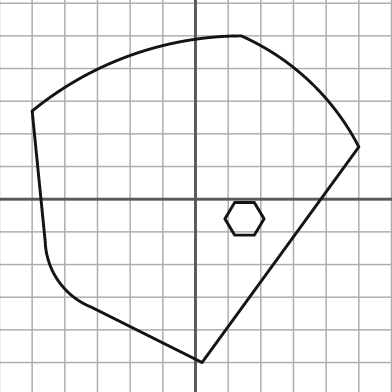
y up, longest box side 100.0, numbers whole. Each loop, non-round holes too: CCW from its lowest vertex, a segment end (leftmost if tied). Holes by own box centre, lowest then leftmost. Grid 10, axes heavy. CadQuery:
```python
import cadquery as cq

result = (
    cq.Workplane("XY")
    .moveTo(2.0, -50.0)
    .lineTo(50.0, 16.0)
    .threePointArc((35.0, 36.0), (14.0, 50.0))
    .threePointArc((-20.0, 44.0), (-50.0, 27.0))
    .lineTo(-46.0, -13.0)
    .threePointArc((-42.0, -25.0), (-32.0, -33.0))
    .close()
    .moveTo(12.0, -11.0)
    .lineTo(18.0, -11.0)
    .lineTo(21.0, -6.0)
    .lineTo(18.0, -1.0)
    .lineTo(12.0, -1.0)
    .lineTo(9.0, -6.0)
    .close()
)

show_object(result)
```